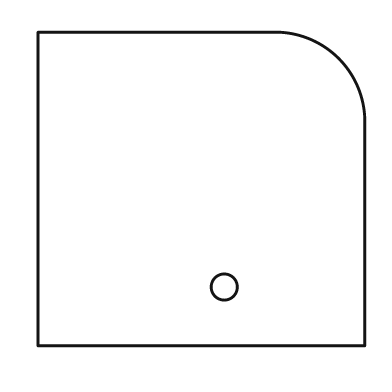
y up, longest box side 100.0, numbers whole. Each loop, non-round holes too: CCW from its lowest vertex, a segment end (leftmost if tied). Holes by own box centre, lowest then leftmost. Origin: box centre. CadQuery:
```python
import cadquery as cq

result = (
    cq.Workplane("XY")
    .moveTo(-50.0, -48.0)
    .lineTo(50.0, -48.0)
    .lineTo(50.0, 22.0)
    .threePointArc((42.0, 40.0), (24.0, 48.0))
    .lineTo(-50.0, 48.0)
    .close()
    .moveTo(7.0, -30.0)
    .circle(4.0)
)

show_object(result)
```